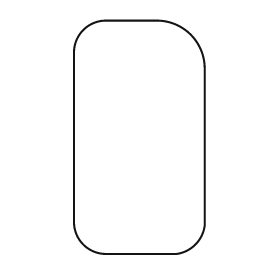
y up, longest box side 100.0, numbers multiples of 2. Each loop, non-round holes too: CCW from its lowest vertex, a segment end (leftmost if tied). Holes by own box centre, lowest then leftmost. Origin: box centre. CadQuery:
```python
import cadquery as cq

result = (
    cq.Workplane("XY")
    .moveTo(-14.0, -50.0)
    .lineTo(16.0, -50.0)
    .threePointArc((24.0, -46.0), (28.0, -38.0))
    .lineTo(28.0, 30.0)
    .threePointArc((22.0, 44.0), (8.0, 50.0))
    .lineTo(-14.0, 50.0)
    .threePointArc((-24.0, 46.0), (-28.0, 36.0))
    .lineTo(-28.0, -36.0)
    .threePointArc((-24.0, -46.0), (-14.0, -50.0))
    .close()
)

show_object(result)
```